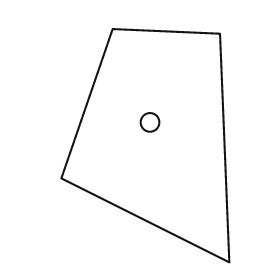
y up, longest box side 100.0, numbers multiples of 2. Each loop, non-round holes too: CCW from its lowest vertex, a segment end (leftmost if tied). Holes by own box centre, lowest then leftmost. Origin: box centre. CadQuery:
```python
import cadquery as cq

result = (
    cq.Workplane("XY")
    .moveTo(36.0, -50.0)
    .lineTo(32.0, 48.0)
    .lineTo(-14.0, 50.0)
    .lineTo(-36.0, -14.0)
    .close()
    .moveTo(2.0, 10.0)
    .circle(4.0)
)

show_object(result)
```